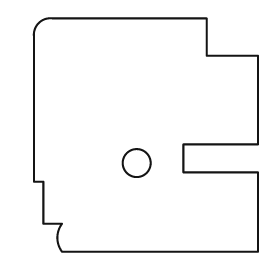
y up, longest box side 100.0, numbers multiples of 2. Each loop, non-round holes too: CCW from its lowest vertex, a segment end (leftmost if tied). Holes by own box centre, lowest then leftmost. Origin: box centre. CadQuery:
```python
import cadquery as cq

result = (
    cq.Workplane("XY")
    .moveTo(-36.0, -50.0)
    .lineTo(48.0, -50.0)
    .lineTo(48.0, -16.0)
    .lineTo(16.0, -16.0)
    .lineTo(16.0, -4.0)
    .lineTo(48.0, -4.0)
    .lineTo(48.0, 34.0)
    .lineTo(26.0, 34.0)
    .lineTo(26.0, 50.0)
    .lineTo(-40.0, 50.0)
    .threePointArc((-46.0, 48.0), (-48.0, 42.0))
    .lineTo(-48.0, -20.0)
    .lineTo(-44.0, -20.0)
    .lineTo(-44.0, -38.0)
    .lineTo(-36.0, -38.0)
    .threePointArc((-38.0, -44.0), (-36.0, -50.0))
    .close()
    .moveTo(-4.0, -12.0)
    .circle(6.0)
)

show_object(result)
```